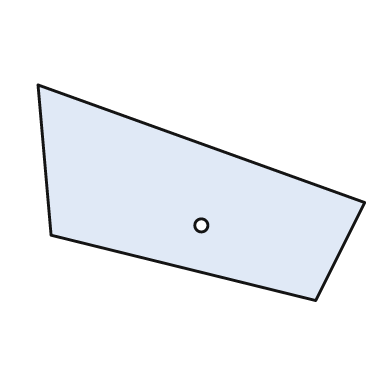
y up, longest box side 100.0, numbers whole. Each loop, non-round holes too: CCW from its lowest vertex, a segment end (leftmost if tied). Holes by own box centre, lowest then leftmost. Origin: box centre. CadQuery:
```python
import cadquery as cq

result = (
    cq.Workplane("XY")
    .moveTo(35.0, -33.0)
    .lineTo(50.0, -3.0)
    .lineTo(-50.0, 33.0)
    .lineTo(-46.0, -13.0)
    .close()
    .moveTo(0.0, -10.0)
    .circle(2.0)
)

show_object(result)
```